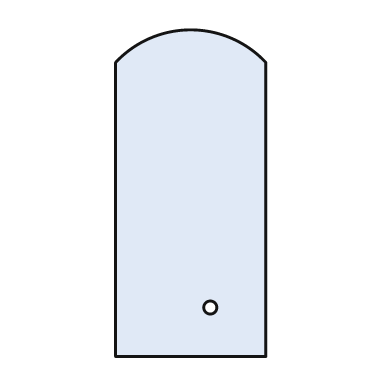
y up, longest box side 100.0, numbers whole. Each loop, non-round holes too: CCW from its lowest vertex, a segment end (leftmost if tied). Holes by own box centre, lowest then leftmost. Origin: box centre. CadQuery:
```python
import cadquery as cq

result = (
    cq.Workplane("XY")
    .moveTo(-23.0, -50.0)
    .lineTo(23.0, -50.0)
    .lineTo(23.0, 40.0)
    .threePointArc((0.0, 50.0), (-23.0, 40.0))
    .close()
    .moveTo(6.0, -35.0)
    .circle(2.0)
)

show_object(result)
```